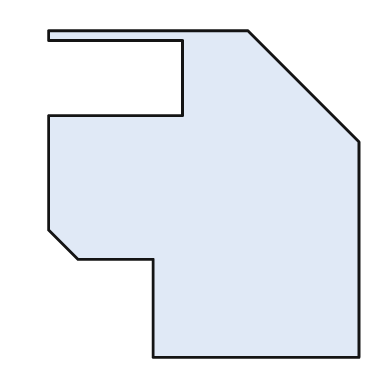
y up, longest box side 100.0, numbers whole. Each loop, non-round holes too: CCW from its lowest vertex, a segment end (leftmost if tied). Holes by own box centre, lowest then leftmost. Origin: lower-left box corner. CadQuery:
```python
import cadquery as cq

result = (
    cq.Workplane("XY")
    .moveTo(32.0, 0.0)
    .lineTo(95.0, 0.0)
    .lineTo(95.0, 66.0)
    .lineTo(61.0, 100.0)
    .lineTo(0.0, 100.0)
    .lineTo(0.0, 97.0)
    .lineTo(41.0, 97.0)
    .lineTo(41.0, 74.0)
    .lineTo(0.0, 74.0)
    .lineTo(0.0, 39.0)
    .lineTo(9.0, 30.0)
    .lineTo(32.0, 30.0)
    .close()
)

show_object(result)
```